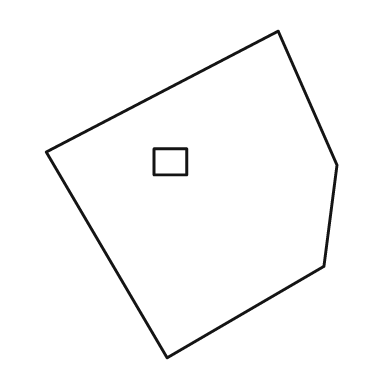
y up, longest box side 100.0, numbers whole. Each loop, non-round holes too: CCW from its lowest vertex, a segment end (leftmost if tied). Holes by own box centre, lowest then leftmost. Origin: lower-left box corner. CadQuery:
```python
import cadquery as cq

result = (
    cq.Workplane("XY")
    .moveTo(37.0, 0.0)
    .lineTo(85.0, 28.0)
    .lineTo(89.0, 59.0)
    .lineTo(71.0, 100.0)
    .lineTo(0.0, 63.0)
    .close()
    .moveTo(33.0, 56.0)
    .lineTo(43.0, 56.0)
    .lineTo(43.0, 64.0)
    .lineTo(33.0, 64.0)
    .close()
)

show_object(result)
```